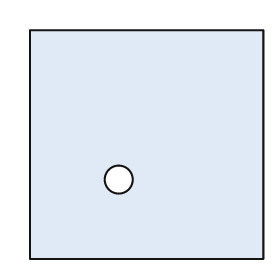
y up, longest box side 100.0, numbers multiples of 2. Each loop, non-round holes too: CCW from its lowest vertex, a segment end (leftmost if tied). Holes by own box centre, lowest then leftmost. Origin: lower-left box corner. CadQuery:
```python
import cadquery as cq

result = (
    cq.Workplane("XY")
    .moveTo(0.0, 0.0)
    .lineTo(100.0, 0.0)
    .lineTo(100.0, 98.0)
    .lineTo(0.0, 98.0)
    .close()
    .moveTo(38.0, 34.0)
    .circle(6.0)
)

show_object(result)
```